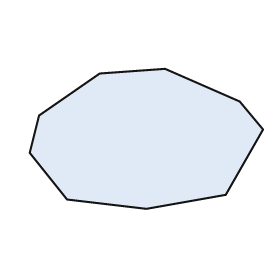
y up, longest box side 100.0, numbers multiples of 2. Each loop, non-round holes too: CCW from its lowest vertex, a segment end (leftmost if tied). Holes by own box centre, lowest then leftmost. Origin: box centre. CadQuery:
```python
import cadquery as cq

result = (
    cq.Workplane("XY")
    .moveTo(0.0, -30.0)
    .lineTo(34.0, -24.0)
    .lineTo(50.0, 4.0)
    .lineTo(40.0, 16.0)
    .lineTo(8.0, 30.0)
    .lineTo(-20.0, 28.0)
    .lineTo(-46.0, 10.0)
    .lineTo(-50.0, -6.0)
    .lineTo(-34.0, -26.0)
    .close()
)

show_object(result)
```